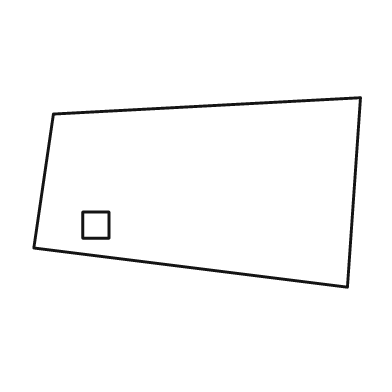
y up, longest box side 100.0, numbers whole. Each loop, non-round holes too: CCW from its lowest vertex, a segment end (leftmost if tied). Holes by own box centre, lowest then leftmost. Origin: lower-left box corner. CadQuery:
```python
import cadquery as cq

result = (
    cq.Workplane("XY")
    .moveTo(96.0, 0.0)
    .lineTo(100.0, 58.0)
    .lineTo(6.0, 53.0)
    .lineTo(0.0, 12.0)
    .close()
    .moveTo(15.0, 15.0)
    .lineTo(23.0, 15.0)
    .lineTo(23.0, 23.0)
    .lineTo(15.0, 23.0)
    .close()
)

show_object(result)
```